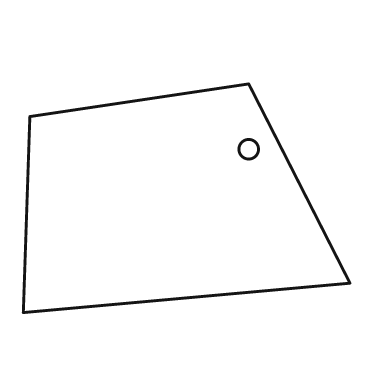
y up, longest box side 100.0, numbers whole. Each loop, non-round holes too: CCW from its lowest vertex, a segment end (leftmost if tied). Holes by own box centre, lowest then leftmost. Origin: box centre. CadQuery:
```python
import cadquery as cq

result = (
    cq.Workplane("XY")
    .moveTo(-50.0, -35.0)
    .lineTo(50.0, -26.0)
    .lineTo(19.0, 35.0)
    .lineTo(-48.0, 25.0)
    .close()
    .moveTo(19.0, 15.0)
    .circle(3.0)
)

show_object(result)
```